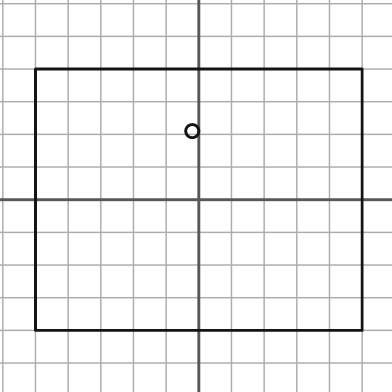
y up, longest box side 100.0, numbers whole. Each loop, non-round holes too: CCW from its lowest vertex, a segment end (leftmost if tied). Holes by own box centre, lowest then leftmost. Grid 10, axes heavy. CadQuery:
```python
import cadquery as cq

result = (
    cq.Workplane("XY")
    .moveTo(-50.0, -40.0)
    .lineTo(50.0, -40.0)
    .lineTo(50.0, 40.0)
    .lineTo(-50.0, 40.0)
    .close()
    .moveTo(-2.0, 21.0)
    .circle(2.0)
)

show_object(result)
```